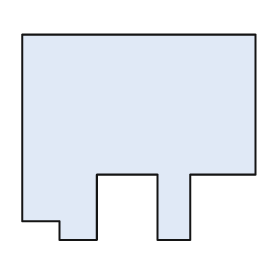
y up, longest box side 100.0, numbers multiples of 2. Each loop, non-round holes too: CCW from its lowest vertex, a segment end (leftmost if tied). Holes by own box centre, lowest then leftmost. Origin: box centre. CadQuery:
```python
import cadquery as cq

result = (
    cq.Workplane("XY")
    .moveTo(-34.0, -44.0)
    .lineTo(-18.0, -44.0)
    .lineTo(-18.0, -16.0)
    .lineTo(8.0, -16.0)
    .lineTo(8.0, -44.0)
    .lineTo(22.0, -44.0)
    .lineTo(22.0, -16.0)
    .lineTo(50.0, -16.0)
    .lineTo(50.0, 44.0)
    .lineTo(-50.0, 44.0)
    .lineTo(-50.0, -36.0)
    .lineTo(-34.0, -36.0)
    .close()
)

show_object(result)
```